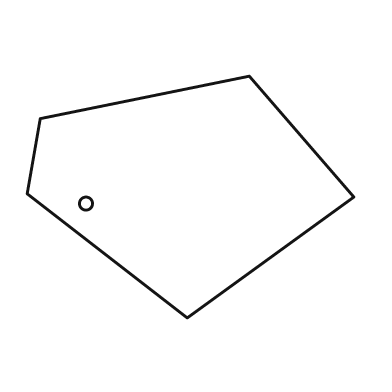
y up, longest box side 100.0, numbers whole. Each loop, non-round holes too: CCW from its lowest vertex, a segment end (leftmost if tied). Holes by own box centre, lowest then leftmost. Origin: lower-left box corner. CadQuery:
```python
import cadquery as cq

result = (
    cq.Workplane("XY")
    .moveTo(49.0, 0.0)
    .lineTo(100.0, 37.0)
    .lineTo(68.0, 74.0)
    .lineTo(4.0, 61.0)
    .lineTo(0.0, 38.0)
    .close()
    .moveTo(18.0, 35.0)
    .circle(2.0)
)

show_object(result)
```